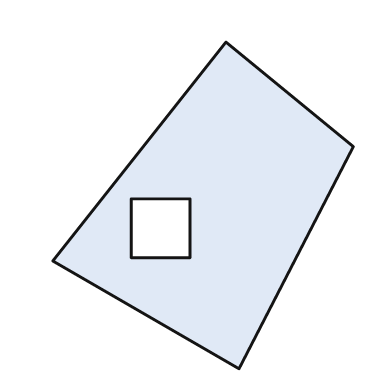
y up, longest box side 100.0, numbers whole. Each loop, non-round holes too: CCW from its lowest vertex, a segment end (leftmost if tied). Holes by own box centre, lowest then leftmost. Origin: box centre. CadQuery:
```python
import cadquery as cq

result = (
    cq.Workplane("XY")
    .moveTo(11.0, -50.0)
    .lineTo(46.0, 18.0)
    .lineTo(7.0, 50.0)
    .lineTo(-46.0, -17.0)
    .close()
    .moveTo(-22.0, -16.0)
    .lineTo(-4.0, -16.0)
    .lineTo(-4.0, 2.0)
    .lineTo(-22.0, 2.0)
    .close()
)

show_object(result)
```